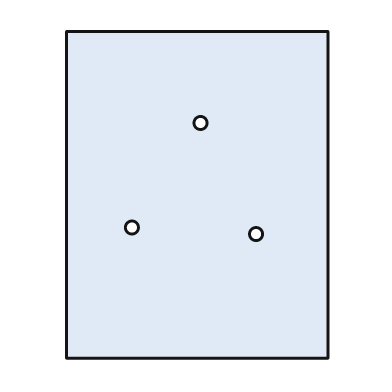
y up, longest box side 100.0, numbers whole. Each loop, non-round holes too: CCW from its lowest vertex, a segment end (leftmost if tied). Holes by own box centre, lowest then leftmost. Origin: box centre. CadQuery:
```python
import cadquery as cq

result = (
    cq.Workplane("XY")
    .moveTo(-40.0, -50.0)
    .lineTo(40.0, -50.0)
    .lineTo(40.0, 50.0)
    .lineTo(-40.0, 50.0)
    .close()
    .moveTo(18.0, -12.0)
    .circle(2.0)
    .moveTo(-20.0, -10.0)
    .circle(2.0)
    .moveTo(1.0, 22.0)
    .circle(2.0)
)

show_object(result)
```